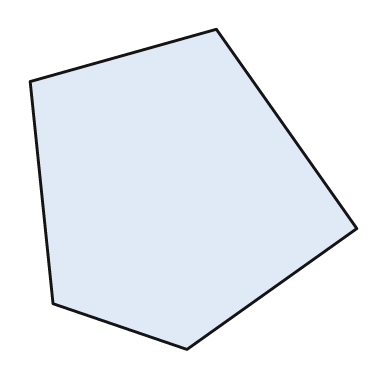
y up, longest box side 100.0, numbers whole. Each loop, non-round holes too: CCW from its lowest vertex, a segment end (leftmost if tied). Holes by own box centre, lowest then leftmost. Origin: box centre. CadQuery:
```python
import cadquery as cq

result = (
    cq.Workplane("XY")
    .moveTo(-2.0, -49.0)
    .lineTo(50.0, -12.0)
    .lineTo(7.0, 49.0)
    .lineTo(-50.0, 33.0)
    .lineTo(-43.0, -35.0)
    .close()
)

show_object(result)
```